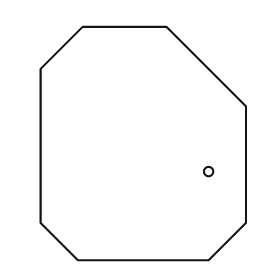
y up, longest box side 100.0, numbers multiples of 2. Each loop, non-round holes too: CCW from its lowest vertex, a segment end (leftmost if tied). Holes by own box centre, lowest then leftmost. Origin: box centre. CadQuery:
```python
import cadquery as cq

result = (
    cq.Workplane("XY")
    .moveTo(-28.0, -50.0)
    .lineTo(28.0, -50.0)
    .lineTo(44.0, -34.0)
    .lineTo(44.0, 16.0)
    .lineTo(10.0, 50.0)
    .lineTo(-26.0, 50.0)
    .lineTo(-44.0, 32.0)
    .lineTo(-44.0, -34.0)
    .close()
    .moveTo(28.0, -12.0)
    .circle(2.0)
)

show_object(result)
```